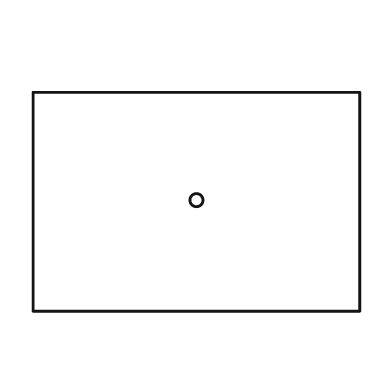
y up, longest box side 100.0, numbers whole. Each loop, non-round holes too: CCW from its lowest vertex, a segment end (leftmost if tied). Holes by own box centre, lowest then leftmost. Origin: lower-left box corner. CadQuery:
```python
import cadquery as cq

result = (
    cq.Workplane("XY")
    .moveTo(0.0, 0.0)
    .lineTo(100.0, 0.0)
    .lineTo(100.0, 67.0)
    .lineTo(0.0, 67.0)
    .close()
    .moveTo(50.0, 34.0)
    .circle(2.0)
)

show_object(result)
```